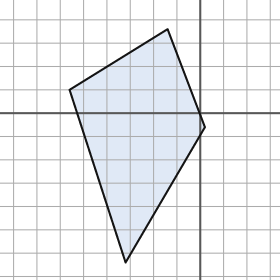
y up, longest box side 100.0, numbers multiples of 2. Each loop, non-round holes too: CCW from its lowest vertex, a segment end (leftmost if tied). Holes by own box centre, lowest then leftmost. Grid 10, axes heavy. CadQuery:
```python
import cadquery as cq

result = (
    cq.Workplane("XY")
    .moveTo(-32.0, -64.0)
    .lineTo(2.0, -6.0)
    .lineTo(-14.0, 36.0)
    .lineTo(-56.0, 10.0)
    .close()
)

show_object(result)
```